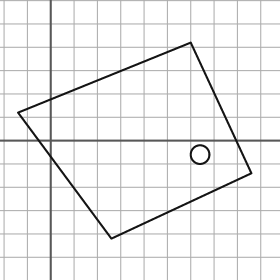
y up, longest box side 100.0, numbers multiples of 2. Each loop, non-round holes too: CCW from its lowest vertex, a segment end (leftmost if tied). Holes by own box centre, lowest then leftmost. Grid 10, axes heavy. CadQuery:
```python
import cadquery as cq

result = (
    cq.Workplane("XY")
    .moveTo(26.0, -42.0)
    .lineTo(86.0, -14.0)
    .lineTo(60.0, 42.0)
    .lineTo(-14.0, 12.0)
    .close()
    .moveTo(64.0, -6.0)
    .circle(4.0)
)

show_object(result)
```